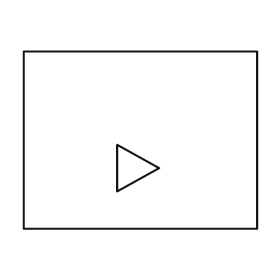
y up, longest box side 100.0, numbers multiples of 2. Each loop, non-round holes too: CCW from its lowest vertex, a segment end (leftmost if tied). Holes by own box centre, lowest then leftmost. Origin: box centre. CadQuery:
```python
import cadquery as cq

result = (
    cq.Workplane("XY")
    .moveTo(-50.0, -38.0)
    .lineTo(50.0, -38.0)
    .lineTo(50.0, 38.0)
    .lineTo(-50.0, 38.0)
    .close()
    .moveTo(-10.0, -22.0)
    .lineTo(8.0, -12.0)
    .lineTo(-10.0, -2.0)
    .close()
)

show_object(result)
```